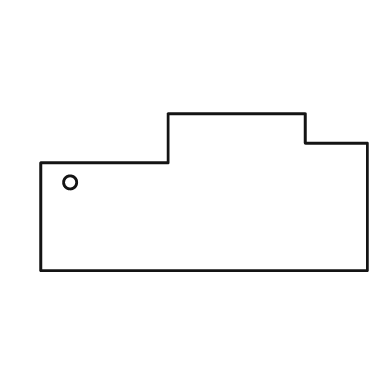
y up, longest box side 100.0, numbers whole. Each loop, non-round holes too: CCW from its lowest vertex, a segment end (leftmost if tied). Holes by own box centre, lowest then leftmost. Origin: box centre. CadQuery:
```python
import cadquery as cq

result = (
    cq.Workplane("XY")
    .moveTo(-50.0, -24.0)
    .lineTo(50.0, -24.0)
    .lineTo(50.0, 15.0)
    .lineTo(31.0, 15.0)
    .lineTo(31.0, 24.0)
    .lineTo(-11.0, 24.0)
    .lineTo(-11.0, 9.0)
    .lineTo(-50.0, 9.0)
    .close()
    .moveTo(-41.0, 3.0)
    .circle(2.0)
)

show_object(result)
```